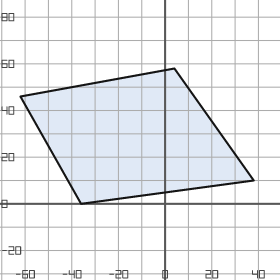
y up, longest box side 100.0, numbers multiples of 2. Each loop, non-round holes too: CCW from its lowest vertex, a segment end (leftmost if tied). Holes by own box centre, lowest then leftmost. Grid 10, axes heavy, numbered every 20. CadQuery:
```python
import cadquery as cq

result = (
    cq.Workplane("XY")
    .moveTo(-36.0, 0.0)
    .lineTo(38.0, 10.0)
    .lineTo(4.0, 58.0)
    .lineTo(-62.0, 46.0)
    .close()
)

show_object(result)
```